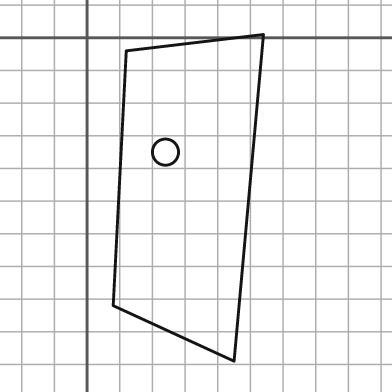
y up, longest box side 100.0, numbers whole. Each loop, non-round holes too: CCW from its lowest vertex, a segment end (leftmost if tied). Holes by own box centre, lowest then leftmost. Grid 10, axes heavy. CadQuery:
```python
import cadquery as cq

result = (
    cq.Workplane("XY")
    .moveTo(45.0, -99.0)
    .lineTo(54.0, 1.0)
    .lineTo(12.0, -4.0)
    .lineTo(8.0, -82.0)
    .close()
    .moveTo(24.0, -35.0)
    .circle(4.0)
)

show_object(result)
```